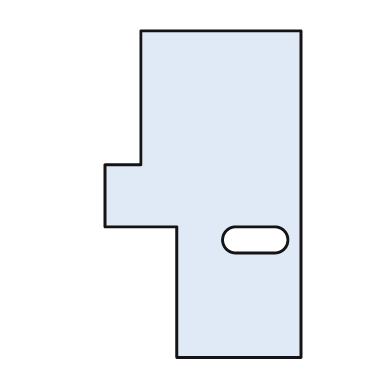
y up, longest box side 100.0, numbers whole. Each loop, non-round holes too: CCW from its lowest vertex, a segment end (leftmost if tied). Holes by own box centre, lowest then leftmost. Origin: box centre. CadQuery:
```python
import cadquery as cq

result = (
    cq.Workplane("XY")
    .moveTo(-8.0, -50.0)
    .lineTo(30.0, -50.0)
    .lineTo(30.0, 50.0)
    .lineTo(-19.0, 50.0)
    .lineTo(-19.0, 9.0)
    .lineTo(-30.0, 9.0)
    .lineTo(-30.0, -10.0)
    .lineTo(-8.0, -10.0)
    .close()
    .moveTo(10.0, -18.0)
    .lineTo(22.0, -18.0)
    .threePointArc((26.0, -14.0), (22.0, -10.0))
    .lineTo(10.0, -10.0)
    .threePointArc((6.0, -14.0), (10.0, -18.0))
    .close()
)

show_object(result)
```